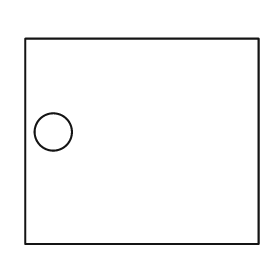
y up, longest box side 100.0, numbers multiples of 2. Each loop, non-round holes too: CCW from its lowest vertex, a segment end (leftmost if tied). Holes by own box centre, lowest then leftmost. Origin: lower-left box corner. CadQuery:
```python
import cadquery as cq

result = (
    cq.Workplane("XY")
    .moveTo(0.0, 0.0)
    .lineTo(100.0, 0.0)
    .lineTo(100.0, 88.0)
    .lineTo(0.0, 88.0)
    .close()
    .moveTo(12.0, 48.0)
    .circle(8.0)
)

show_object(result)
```